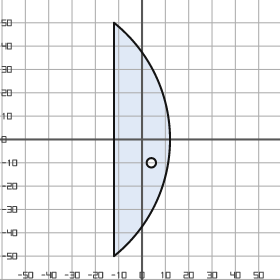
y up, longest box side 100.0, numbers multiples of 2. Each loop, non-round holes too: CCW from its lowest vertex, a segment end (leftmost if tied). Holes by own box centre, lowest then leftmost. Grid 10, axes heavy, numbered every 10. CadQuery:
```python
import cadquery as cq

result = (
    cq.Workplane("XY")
    .moveTo(-12.0, -50.0)
    .threePointArc((12.0, 0.0), (-12.0, 50.0))
    .close()
    .moveTo(4.0, -10.0)
    .circle(2.0)
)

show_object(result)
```